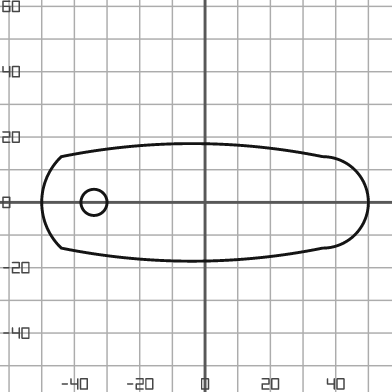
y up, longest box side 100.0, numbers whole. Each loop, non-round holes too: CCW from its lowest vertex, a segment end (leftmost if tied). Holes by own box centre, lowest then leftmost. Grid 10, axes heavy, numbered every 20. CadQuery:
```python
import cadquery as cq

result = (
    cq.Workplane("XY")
    .moveTo(-44.0, -14.0)
    .threePointArc((-4.0, -18.0), (36.0, -14.0))
    .threePointArc((50.0, 0.0), (36.0, 14.0))
    .threePointArc((-4.0, 18.0), (-44.0, 14.0))
    .threePointArc((-50.0, 0.0), (-44.0, -14.0))
    .close()
    .moveTo(-34.0, 0.0)
    .circle(4.0)
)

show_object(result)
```